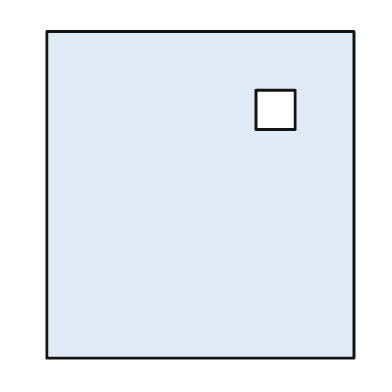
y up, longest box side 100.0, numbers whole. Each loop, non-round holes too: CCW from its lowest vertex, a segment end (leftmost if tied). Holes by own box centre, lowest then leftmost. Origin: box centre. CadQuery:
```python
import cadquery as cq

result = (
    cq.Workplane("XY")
    .moveTo(-47.0, -50.0)
    .lineTo(47.0, -50.0)
    .lineTo(47.0, 50.0)
    .lineTo(-47.0, 50.0)
    .close()
    .moveTo(17.0, 20.0)
    .lineTo(29.0, 20.0)
    .lineTo(29.0, 32.0)
    .lineTo(17.0, 32.0)
    .close()
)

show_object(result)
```